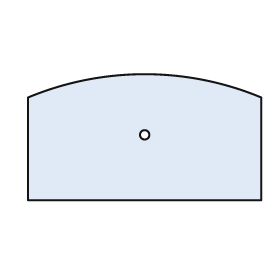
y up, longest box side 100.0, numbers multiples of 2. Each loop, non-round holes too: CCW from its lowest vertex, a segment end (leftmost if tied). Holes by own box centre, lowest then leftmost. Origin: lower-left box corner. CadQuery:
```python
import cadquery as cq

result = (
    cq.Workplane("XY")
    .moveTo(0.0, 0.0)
    .lineTo(100.0, 0.0)
    .lineTo(100.0, 44.0)
    .threePointArc((50.0, 54.0), (0.0, 44.0))
    .close()
    .moveTo(50.0, 28.0)
    .circle(2.0)
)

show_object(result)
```